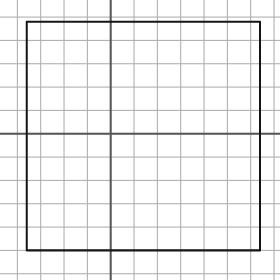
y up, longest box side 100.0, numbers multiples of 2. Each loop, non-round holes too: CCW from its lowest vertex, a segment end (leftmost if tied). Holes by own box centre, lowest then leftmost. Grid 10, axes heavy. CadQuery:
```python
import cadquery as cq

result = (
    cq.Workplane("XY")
    .moveTo(-36.0, -50.0)
    .lineTo(64.0, -50.0)
    .lineTo(64.0, 48.0)
    .lineTo(-36.0, 48.0)
    .close()
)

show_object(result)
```